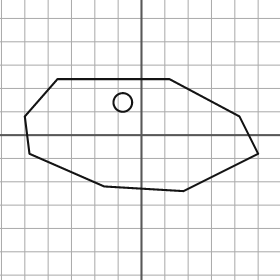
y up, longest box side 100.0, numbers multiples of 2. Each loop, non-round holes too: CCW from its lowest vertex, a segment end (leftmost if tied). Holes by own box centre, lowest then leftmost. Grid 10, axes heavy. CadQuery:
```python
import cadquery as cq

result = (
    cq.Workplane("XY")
    .moveTo(18.0, -24.0)
    .lineTo(50.0, -8.0)
    .lineTo(42.0, 8.0)
    .lineTo(12.0, 24.0)
    .lineTo(-36.0, 24.0)
    .lineTo(-50.0, 8.0)
    .lineTo(-48.0, -8.0)
    .lineTo(-16.0, -22.0)
    .close()
    .moveTo(-8.0, 14.0)
    .circle(4.0)
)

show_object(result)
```